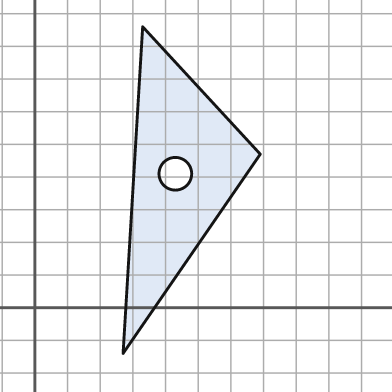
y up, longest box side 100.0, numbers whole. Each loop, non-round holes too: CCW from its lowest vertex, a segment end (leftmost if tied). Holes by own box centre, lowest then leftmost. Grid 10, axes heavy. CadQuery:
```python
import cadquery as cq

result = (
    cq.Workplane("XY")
    .moveTo(27.0, -14.0)
    .lineTo(69.0, 47.0)
    .lineTo(33.0, 86.0)
    .close()
    .moveTo(43.0, 41.0)
    .circle(5.0)
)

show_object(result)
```